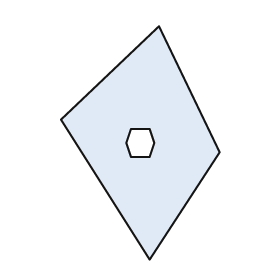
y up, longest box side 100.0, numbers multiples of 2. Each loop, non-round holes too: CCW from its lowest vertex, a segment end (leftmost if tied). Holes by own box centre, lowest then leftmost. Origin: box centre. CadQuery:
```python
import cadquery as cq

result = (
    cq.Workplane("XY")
    .moveTo(4.0, -50.0)
    .lineTo(34.0, -4.0)
    .lineTo(8.0, 50.0)
    .lineTo(-34.0, 10.0)
    .close()
    .moveTo(-4.0, -6.0)
    .lineTo(4.0, -6.0)
    .lineTo(6.0, 0.0)
    .lineTo(4.0, 6.0)
    .lineTo(-4.0, 6.0)
    .lineTo(-6.0, 0.0)
    .close()
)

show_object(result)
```